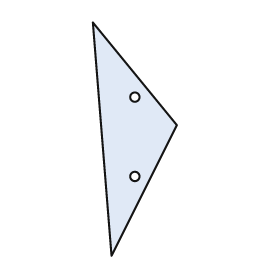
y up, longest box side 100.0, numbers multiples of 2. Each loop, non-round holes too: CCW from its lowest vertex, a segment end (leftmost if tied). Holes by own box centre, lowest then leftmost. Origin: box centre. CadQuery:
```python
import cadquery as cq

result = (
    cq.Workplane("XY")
    .moveTo(-10.0, -50.0)
    .lineTo(18.0, 6.0)
    .lineTo(-18.0, 50.0)
    .close()
    .moveTo(0.0, -16.0)
    .circle(2.0)
    .moveTo(0.0, 18.0)
    .circle(2.0)
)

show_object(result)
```